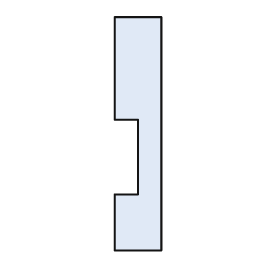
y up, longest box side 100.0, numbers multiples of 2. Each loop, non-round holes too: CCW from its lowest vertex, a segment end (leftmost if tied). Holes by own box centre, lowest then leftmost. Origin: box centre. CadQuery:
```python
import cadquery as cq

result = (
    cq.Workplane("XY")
    .moveTo(-10.0, -50.0)
    .lineTo(10.0, -50.0)
    .lineTo(10.0, 50.0)
    .lineTo(-10.0, 50.0)
    .lineTo(-10.0, 6.0)
    .lineTo(0.0, 6.0)
    .lineTo(0.0, -26.0)
    .lineTo(-10.0, -26.0)
    .close()
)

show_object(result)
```